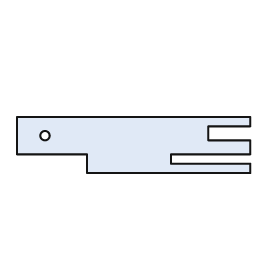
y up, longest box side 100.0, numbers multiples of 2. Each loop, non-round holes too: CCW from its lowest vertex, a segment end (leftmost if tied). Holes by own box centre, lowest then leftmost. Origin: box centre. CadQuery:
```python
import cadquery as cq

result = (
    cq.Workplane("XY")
    .moveTo(-20.0, -12.0)
    .lineTo(50.0, -12.0)
    .lineTo(50.0, -8.0)
    .lineTo(16.0, -8.0)
    .lineTo(16.0, -4.0)
    .lineTo(50.0, -4.0)
    .lineTo(50.0, 2.0)
    .lineTo(32.0, 2.0)
    .lineTo(32.0, 8.0)
    .lineTo(50.0, 8.0)
    .lineTo(50.0, 12.0)
    .lineTo(-50.0, 12.0)
    .lineTo(-50.0, -4.0)
    .lineTo(-20.0, -4.0)
    .close()
    .moveTo(-38.0, 4.0)
    .circle(2.0)
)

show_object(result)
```